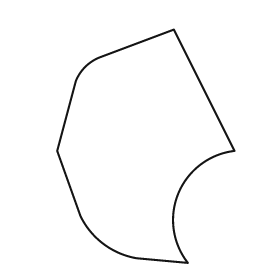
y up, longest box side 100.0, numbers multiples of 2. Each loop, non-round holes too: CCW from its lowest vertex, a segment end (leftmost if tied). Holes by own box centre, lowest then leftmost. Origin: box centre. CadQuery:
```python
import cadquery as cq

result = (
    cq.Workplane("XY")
    .moveTo(18.0, -50.0)
    .threePointArc((14.0, -20.0), (38.0, -2.0))
    .lineTo(12.0, 50.0)
    .lineTo(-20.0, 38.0)
    .threePointArc((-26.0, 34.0), (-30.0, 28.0))
    .lineTo(-38.0, -2.0)
    .lineTo(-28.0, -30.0)
    .threePointArc((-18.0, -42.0), (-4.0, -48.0))
    .close()
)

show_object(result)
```